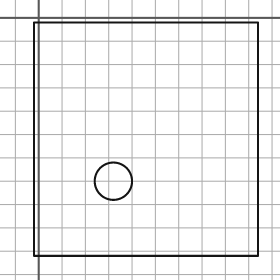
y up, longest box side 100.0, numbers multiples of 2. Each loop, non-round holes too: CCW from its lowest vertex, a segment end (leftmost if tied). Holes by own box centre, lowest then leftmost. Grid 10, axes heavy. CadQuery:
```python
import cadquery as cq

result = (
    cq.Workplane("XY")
    .moveTo(-2.0, -102.0)
    .lineTo(94.0, -102.0)
    .lineTo(94.0, -2.0)
    .lineTo(-2.0, -2.0)
    .close()
    .moveTo(32.0, -70.0)
    .circle(8.0)
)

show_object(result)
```